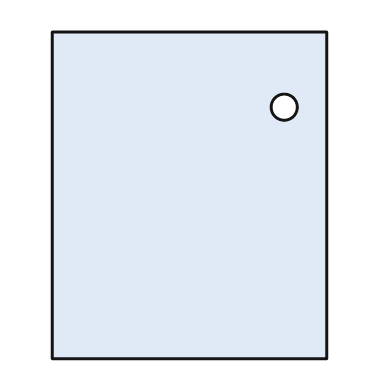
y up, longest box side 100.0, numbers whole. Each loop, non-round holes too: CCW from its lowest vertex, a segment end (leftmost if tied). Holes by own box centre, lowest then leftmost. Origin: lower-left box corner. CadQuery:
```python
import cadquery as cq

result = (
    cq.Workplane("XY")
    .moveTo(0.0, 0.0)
    .lineTo(84.0, 0.0)
    .lineTo(84.0, 100.0)
    .lineTo(0.0, 100.0)
    .close()
    .moveTo(71.0, 77.0)
    .circle(4.0)
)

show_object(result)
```